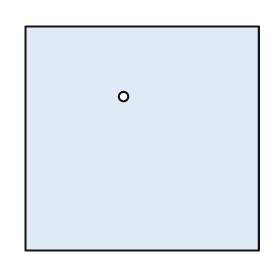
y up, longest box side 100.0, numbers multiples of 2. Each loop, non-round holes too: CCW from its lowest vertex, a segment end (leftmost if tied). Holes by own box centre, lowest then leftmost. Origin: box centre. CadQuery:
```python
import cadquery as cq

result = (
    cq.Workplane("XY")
    .moveTo(-50.0, -48.0)
    .lineTo(50.0, -48.0)
    .lineTo(50.0, 48.0)
    .lineTo(-50.0, 48.0)
    .close()
    .moveTo(-8.0, 18.0)
    .circle(2.0)
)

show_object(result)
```